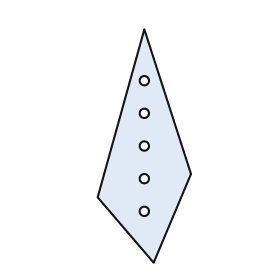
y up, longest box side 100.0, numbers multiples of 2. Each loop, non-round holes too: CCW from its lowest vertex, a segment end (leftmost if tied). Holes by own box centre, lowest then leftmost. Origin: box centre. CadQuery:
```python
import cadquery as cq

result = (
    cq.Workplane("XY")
    .moveTo(4.0, -50.0)
    .lineTo(20.0, -12.0)
    .lineTo(0.0, 50.0)
    .lineTo(-20.0, -22.0)
    .close()
    .moveTo(0.0, -28.0)
    .circle(2.0)
    .moveTo(0.0, -14.0)
    .circle(2.0)
    .moveTo(0.0, 0.0)
    .circle(2.0)
    .moveTo(0.0, 14.0)
    .circle(2.0)
    .moveTo(0.0, 28.0)
    .circle(2.0)
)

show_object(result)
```